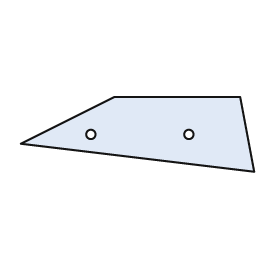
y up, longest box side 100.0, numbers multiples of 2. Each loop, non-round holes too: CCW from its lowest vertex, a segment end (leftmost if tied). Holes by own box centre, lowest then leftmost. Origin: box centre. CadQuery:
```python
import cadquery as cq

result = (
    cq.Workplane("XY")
    .moveTo(50.0, -16.0)
    .lineTo(44.0, 16.0)
    .lineTo(-10.0, 16.0)
    .lineTo(-50.0, -4.0)
    .close()
    .moveTo(-20.0, 0.0)
    .circle(2.0)
    .moveTo(22.0, 0.0)
    .circle(2.0)
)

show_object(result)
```